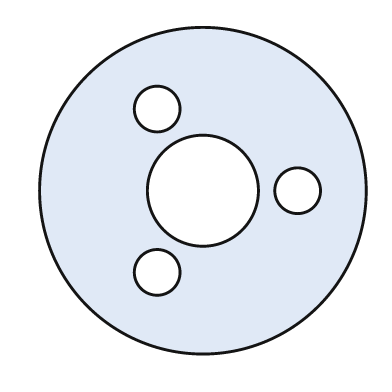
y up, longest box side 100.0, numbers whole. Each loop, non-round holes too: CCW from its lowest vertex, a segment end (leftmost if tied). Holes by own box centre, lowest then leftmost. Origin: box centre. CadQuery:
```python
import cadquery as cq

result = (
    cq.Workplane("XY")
    .moveTo(0.0, 0.0)
    .circle(50.0)
    .moveTo(-14.0, -25.0)
    .circle(7.0)
    .moveTo(0.0, 0.0)
    .circle(17.0)
    .moveTo(29.0, 0.0)
    .circle(7.0)
    .moveTo(-14.0, 25.0)
    .circle(7.0)
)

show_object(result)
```